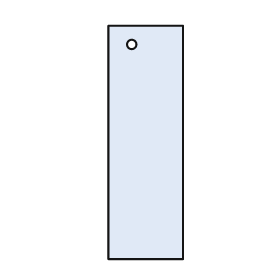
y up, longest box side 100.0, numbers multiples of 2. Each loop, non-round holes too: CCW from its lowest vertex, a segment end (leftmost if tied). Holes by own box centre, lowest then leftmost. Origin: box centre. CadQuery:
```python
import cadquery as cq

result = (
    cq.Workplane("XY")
    .moveTo(-16.0, -50.0)
    .lineTo(16.0, -50.0)
    .lineTo(16.0, 50.0)
    .lineTo(-16.0, 50.0)
    .close()
    .moveTo(-6.0, 42.0)
    .circle(2.0)
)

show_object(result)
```